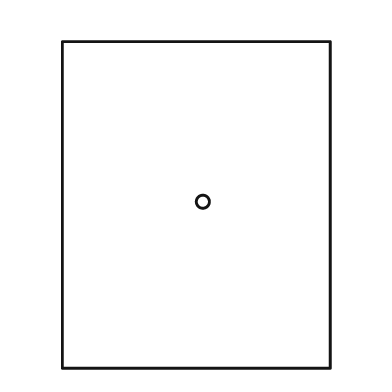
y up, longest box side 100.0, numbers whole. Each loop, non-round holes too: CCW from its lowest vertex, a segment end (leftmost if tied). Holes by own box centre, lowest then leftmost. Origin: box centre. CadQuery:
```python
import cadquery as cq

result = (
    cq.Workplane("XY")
    .moveTo(-41.0, -50.0)
    .lineTo(41.0, -50.0)
    .lineTo(41.0, 50.0)
    .lineTo(-41.0, 50.0)
    .close()
    .moveTo(2.0, 1.0)
    .circle(2.0)
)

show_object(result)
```